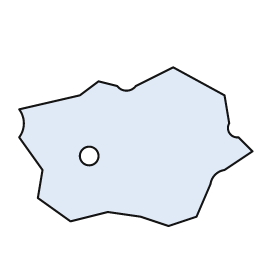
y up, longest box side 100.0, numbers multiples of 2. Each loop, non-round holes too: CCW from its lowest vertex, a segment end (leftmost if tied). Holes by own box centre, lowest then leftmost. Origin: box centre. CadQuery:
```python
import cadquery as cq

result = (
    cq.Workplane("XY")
    .moveTo(14.0, -34.0)
    .lineTo(26.0, -30.0)
    .lineTo(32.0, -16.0)
    .threePointArc((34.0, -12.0), (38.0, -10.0))
    .lineTo(50.0, -2.0)
    .lineTo(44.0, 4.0)
    .threePointArc((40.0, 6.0), (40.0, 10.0))
    .lineTo(38.0, 22.0)
    .lineTo(16.0, 34.0)
    .lineTo(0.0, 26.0)
    .threePointArc((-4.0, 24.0), (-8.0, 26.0))
    .lineTo(-16.0, 28.0)
    .lineTo(-24.0, 22.0)
    .lineTo(-50.0, 16.0)
    .threePointArc((-48.0, 10.0), (-50.0, 4.0))
    .lineTo(-40.0, -10.0)
    .lineTo(-42.0, -22.0)
    .lineTo(-28.0, -32.0)
    .lineTo(-12.0, -28.0)
    .lineTo(2.0, -30.0)
    .close()
    .moveTo(-20.0, -4.0)
    .circle(4.0)
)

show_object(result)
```